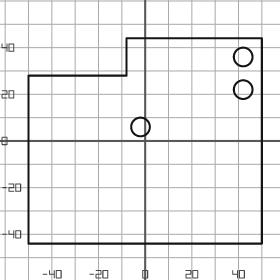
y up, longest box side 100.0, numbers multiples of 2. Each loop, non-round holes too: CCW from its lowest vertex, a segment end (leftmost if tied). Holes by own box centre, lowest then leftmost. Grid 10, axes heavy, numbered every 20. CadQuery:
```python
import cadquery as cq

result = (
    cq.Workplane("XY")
    .moveTo(-50.0, -44.0)
    .lineTo(50.0, -44.0)
    .lineTo(50.0, 44.0)
    .lineTo(-8.0, 44.0)
    .lineTo(-8.0, 28.0)
    .lineTo(-50.0, 28.0)
    .close()
    .moveTo(-2.0, 6.0)
    .circle(4.0)
    .moveTo(42.0, 22.0)
    .circle(4.0)
    .moveTo(42.0, 36.0)
    .circle(4.0)
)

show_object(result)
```